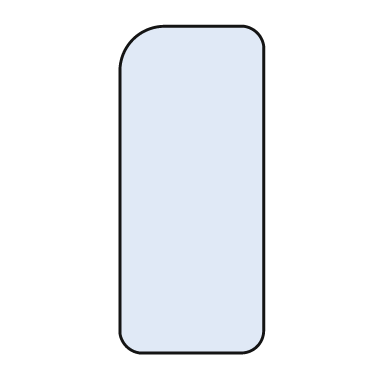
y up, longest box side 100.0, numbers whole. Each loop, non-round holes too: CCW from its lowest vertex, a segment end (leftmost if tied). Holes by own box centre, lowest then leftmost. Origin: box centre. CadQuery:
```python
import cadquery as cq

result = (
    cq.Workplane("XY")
    .moveTo(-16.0, -50.0)
    .lineTo(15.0, -50.0)
    .threePointArc((20.0, -48.0), (22.0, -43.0))
    .lineTo(22.0, 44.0)
    .threePointArc((20.0, 48.0), (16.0, 50.0))
    .lineTo(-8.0, 50.0)
    .threePointArc((-18.0, 46.0), (-22.0, 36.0))
    .lineTo(-22.0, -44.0)
    .threePointArc((-20.0, -48.0), (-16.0, -50.0))
    .close()
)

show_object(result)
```